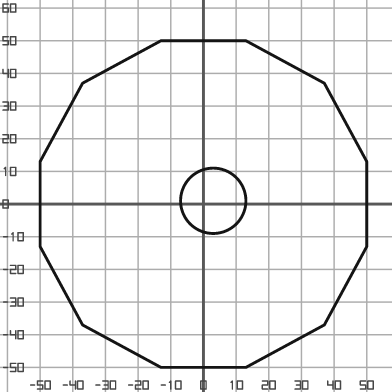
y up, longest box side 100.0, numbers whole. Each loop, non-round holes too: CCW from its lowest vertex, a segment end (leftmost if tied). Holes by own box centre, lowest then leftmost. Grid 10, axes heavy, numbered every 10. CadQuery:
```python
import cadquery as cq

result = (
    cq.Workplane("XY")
    .moveTo(-13.0, -50.0)
    .lineTo(13.0, -50.0)
    .lineTo(37.0, -37.0)
    .lineTo(50.0, -13.0)
    .lineTo(50.0, 13.0)
    .lineTo(37.0, 37.0)
    .lineTo(13.0, 50.0)
    .lineTo(-13.0, 50.0)
    .lineTo(-37.0, 37.0)
    .lineTo(-50.0, 13.0)
    .lineTo(-50.0, -13.0)
    .lineTo(-37.0, -37.0)
    .close()
    .moveTo(3.0, 1.0)
    .circle(10.0)
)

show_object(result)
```